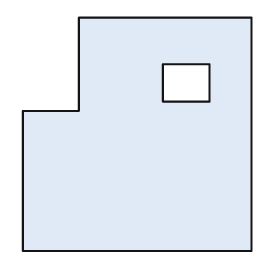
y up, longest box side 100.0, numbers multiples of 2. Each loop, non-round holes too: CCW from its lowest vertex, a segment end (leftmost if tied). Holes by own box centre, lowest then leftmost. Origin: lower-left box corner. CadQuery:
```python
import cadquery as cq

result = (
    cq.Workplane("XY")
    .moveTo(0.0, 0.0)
    .lineTo(98.0, 0.0)
    .lineTo(98.0, 100.0)
    .lineTo(24.0, 100.0)
    .lineTo(24.0, 60.0)
    .lineTo(0.0, 60.0)
    .close()
    .moveTo(60.0, 64.0)
    .lineTo(80.0, 64.0)
    .lineTo(80.0, 80.0)
    .lineTo(60.0, 80.0)
    .close()
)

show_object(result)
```